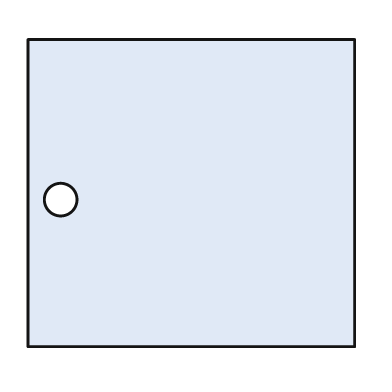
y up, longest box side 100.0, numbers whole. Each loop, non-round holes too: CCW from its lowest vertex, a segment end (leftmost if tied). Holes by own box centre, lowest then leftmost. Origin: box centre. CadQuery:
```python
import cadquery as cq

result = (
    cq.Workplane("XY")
    .moveTo(-50.0, -47.0)
    .lineTo(50.0, -47.0)
    .lineTo(50.0, 47.0)
    .lineTo(-50.0, 47.0)
    .close()
    .moveTo(-40.0, -2.0)
    .circle(5.0)
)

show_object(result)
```